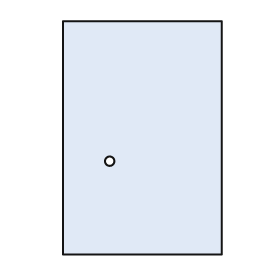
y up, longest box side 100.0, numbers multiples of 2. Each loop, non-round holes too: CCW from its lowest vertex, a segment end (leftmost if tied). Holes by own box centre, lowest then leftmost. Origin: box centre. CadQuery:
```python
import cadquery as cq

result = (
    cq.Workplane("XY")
    .moveTo(-34.0, -50.0)
    .lineTo(34.0, -50.0)
    .lineTo(34.0, 50.0)
    .lineTo(-34.0, 50.0)
    .close()
    .moveTo(-14.0, -10.0)
    .circle(2.0)
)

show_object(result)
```